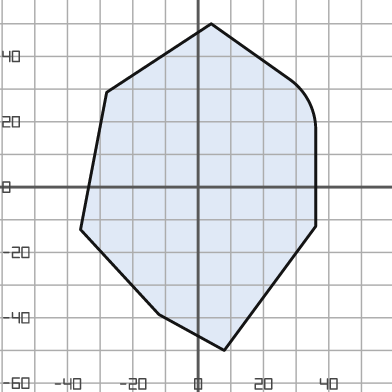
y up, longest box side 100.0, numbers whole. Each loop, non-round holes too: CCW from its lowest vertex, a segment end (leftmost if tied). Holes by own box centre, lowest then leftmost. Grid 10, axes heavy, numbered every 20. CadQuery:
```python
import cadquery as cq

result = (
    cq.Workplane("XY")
    .moveTo(8.0, -50.0)
    .lineTo(36.0, -12.0)
    .lineTo(36.0, 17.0)
    .threePointArc((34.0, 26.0), (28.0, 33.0))
    .lineTo(4.0, 50.0)
    .lineTo(-28.0, 29.0)
    .lineTo(-36.0, -13.0)
    .lineTo(-12.0, -39.0)
    .close()
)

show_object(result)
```